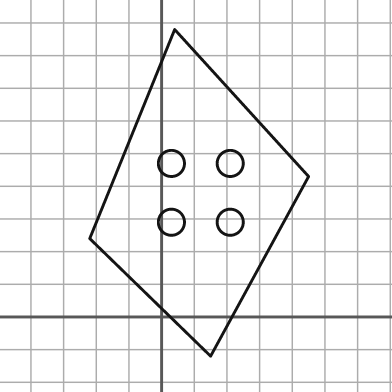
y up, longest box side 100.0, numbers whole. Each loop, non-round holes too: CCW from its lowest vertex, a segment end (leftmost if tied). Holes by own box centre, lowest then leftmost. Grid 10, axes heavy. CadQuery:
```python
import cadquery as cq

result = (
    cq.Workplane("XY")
    .moveTo(15.0, -12.0)
    .lineTo(45.0, 43.0)
    .lineTo(4.0, 88.0)
    .lineTo(-22.0, 24.0)
    .close()
    .moveTo(3.0, 29.0)
    .circle(4.0)
    .moveTo(21.0, 29.0)
    .circle(4.0)
    .moveTo(3.0, 47.0)
    .circle(4.0)
    .moveTo(21.0, 47.0)
    .circle(4.0)
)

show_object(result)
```